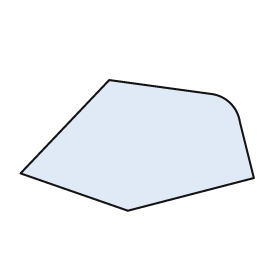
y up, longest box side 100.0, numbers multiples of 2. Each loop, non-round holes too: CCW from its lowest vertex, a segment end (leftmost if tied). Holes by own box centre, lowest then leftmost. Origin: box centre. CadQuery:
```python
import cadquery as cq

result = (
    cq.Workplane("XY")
    .moveTo(-4.0, -28.0)
    .lineTo(50.0, -14.0)
    .lineTo(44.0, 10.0)
    .threePointArc((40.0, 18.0), (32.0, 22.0))
    .lineTo(-12.0, 28.0)
    .lineTo(-50.0, -12.0)
    .close()
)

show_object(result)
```